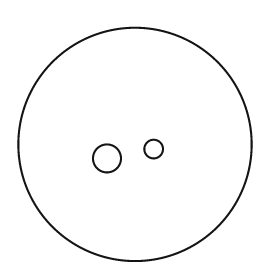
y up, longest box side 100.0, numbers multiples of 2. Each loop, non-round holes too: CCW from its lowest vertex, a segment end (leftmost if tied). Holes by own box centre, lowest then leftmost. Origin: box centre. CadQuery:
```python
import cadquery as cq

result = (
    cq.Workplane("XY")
    .moveTo(0.0, 0.0)
    .circle(50.0)
    .moveTo(-12.0, -6.0)
    .circle(6.0)
    .moveTo(8.0, -2.0)
    .circle(4.0)
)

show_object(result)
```